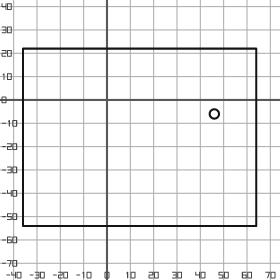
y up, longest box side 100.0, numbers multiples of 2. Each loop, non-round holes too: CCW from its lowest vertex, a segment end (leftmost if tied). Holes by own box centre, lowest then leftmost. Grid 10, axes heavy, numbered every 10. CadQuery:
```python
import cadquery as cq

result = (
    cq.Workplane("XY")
    .moveTo(-36.0, -54.0)
    .lineTo(64.0, -54.0)
    .lineTo(64.0, 22.0)
    .lineTo(-36.0, 22.0)
    .close()
    .moveTo(46.0, -6.0)
    .circle(2.0)
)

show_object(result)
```